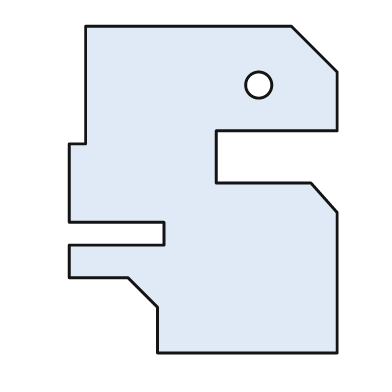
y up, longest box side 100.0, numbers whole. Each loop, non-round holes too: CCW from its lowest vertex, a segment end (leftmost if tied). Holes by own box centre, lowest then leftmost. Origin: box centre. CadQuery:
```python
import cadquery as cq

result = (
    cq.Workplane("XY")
    .moveTo(-14.0, -50.0)
    .lineTo(41.0, -50.0)
    .lineTo(41.0, -7.0)
    .lineTo(33.0, 2.0)
    .lineTo(4.0, 2.0)
    .lineTo(4.0, 18.0)
    .lineTo(41.0, 18.0)
    .lineTo(41.0, 36.0)
    .lineTo(27.0, 50.0)
    .lineTo(-36.0, 50.0)
    .lineTo(-36.0, 14.0)
    .lineTo(-41.0, 14.0)
    .lineTo(-41.0, -10.0)
    .lineTo(-12.0, -10.0)
    .lineTo(-12.0, -17.0)
    .lineTo(-41.0, -17.0)
    .lineTo(-41.0, -27.0)
    .lineTo(-23.0, -27.0)
    .lineTo(-14.0, -36.0)
    .close()
    .moveTo(17.0, 32.0)
    .circle(4.0)
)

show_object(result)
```